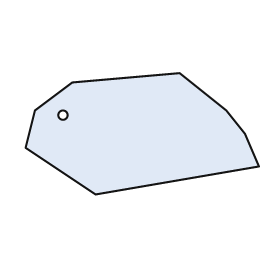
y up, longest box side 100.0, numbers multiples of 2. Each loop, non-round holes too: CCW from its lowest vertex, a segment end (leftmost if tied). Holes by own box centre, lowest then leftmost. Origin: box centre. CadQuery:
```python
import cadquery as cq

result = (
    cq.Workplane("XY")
    .moveTo(-20.0, -26.0)
    .lineTo(50.0, -14.0)
    .lineTo(44.0, 0.0)
    .lineTo(36.0, 10.0)
    .lineTo(16.0, 26.0)
    .lineTo(-30.0, 22.0)
    .lineTo(-46.0, 10.0)
    .lineTo(-50.0, -6.0)
    .close()
    .moveTo(-34.0, 8.0)
    .circle(2.0)
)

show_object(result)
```